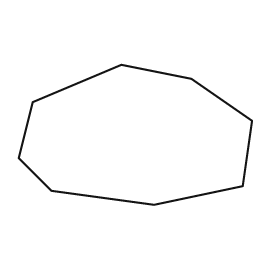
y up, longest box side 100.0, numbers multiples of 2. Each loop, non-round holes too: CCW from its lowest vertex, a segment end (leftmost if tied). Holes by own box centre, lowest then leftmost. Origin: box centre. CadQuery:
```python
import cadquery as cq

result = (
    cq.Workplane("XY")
    .moveTo(8.0, -30.0)
    .lineTo(46.0, -22.0)
    .lineTo(50.0, 6.0)
    .lineTo(24.0, 24.0)
    .lineTo(-6.0, 30.0)
    .lineTo(-44.0, 14.0)
    .lineTo(-50.0, -10.0)
    .lineTo(-36.0, -24.0)
    .close()
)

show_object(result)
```